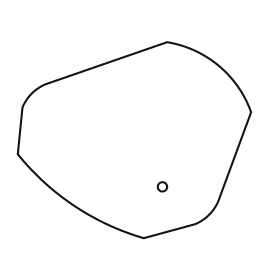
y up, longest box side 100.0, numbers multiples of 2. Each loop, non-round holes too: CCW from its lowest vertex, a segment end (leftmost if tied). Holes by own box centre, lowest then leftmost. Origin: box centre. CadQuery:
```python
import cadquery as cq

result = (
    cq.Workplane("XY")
    .moveTo(4.0, -42.0)
    .lineTo(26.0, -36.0)
    .threePointArc((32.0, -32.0), (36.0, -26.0))
    .lineTo(50.0, 12.0)
    .threePointArc((36.0, 32.0), (14.0, 42.0))
    .lineTo(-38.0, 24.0)
    .threePointArc((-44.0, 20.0), (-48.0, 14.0))
    .lineTo(-50.0, -6.0)
    .threePointArc((-26.0, -28.0), (4.0, -42.0))
    .close()
    .moveTo(12.0, -20.0)
    .circle(2.0)
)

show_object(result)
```